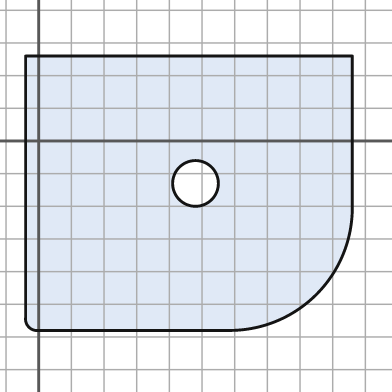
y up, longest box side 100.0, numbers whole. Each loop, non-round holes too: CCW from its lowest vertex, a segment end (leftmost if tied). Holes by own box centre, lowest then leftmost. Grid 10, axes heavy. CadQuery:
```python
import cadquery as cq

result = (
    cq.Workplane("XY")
    .moveTo(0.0, -58.0)
    .lineTo(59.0, -58.0)
    .threePointArc((85.0, -47.0), (96.0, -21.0))
    .lineTo(96.0, 26.0)
    .lineTo(-4.0, 26.0)
    .lineTo(-4.0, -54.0)
    .threePointArc((-3.0, -57.0), (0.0, -58.0))
    .close()
    .moveTo(48.0, -13.0)
    .circle(7.0)
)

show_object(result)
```